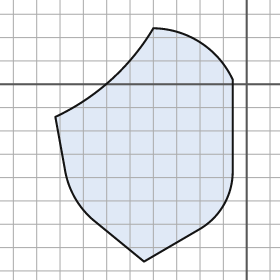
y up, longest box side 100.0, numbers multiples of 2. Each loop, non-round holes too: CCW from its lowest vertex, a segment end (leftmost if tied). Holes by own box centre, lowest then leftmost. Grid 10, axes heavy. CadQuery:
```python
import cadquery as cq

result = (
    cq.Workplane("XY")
    .moveTo(-44.0, -76.0)
    .lineTo(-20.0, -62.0)
    .threePointArc((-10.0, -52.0), (-6.0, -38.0))
    .lineTo(-6.0, 2.0)
    .threePointArc((-20.0, 18.0), (-40.0, 24.0))
    .threePointArc((-58.0, 2.0), (-82.0, -14.0))
    .lineTo(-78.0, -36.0)
    .threePointArc((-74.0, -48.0), (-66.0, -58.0))
    .close()
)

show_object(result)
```